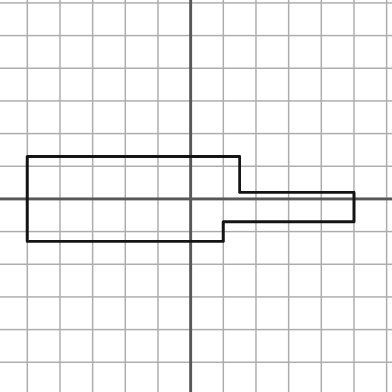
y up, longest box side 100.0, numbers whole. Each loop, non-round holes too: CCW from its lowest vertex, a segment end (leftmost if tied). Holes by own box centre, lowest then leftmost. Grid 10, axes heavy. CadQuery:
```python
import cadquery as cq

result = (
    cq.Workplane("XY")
    .moveTo(-50.0, -13.0)
    .lineTo(10.0, -13.0)
    .lineTo(10.0, -7.0)
    .lineTo(50.0, -7.0)
    .lineTo(50.0, 2.0)
    .lineTo(15.0, 2.0)
    .lineTo(15.0, 13.0)
    .lineTo(-50.0, 13.0)
    .close()
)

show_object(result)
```